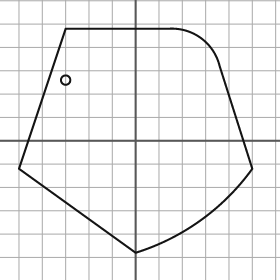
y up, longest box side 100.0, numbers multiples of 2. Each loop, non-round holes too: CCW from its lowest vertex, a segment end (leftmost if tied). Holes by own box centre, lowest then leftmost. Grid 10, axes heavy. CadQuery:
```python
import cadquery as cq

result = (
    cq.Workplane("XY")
    .moveTo(0.0, -48.0)
    .threePointArc((28.0, -34.0), (50.0, -12.0))
    .lineTo(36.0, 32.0)
    .threePointArc((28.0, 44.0), (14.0, 48.0))
    .lineTo(-30.0, 48.0)
    .lineTo(-50.0, -12.0)
    .close()
    .moveTo(-30.0, 26.0)
    .circle(2.0)
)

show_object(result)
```